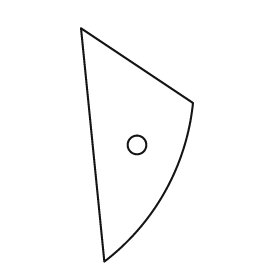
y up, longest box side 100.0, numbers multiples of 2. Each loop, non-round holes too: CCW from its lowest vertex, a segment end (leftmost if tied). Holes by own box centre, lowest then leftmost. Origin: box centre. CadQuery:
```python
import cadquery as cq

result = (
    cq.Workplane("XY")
    .moveTo(-14.0, -50.0)
    .threePointArc((12.0, -20.0), (24.0, 18.0))
    .lineTo(-24.0, 50.0)
    .close()
    .moveTo(0.0, 0.0)
    .circle(4.0)
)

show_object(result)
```